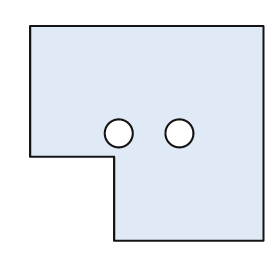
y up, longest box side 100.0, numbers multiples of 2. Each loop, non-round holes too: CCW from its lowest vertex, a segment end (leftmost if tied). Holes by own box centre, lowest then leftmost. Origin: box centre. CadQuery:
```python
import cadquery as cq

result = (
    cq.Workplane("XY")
    .moveTo(-14.0, -46.0)
    .lineTo(50.0, -46.0)
    .lineTo(50.0, 46.0)
    .lineTo(-50.0, 46.0)
    .lineTo(-50.0, -10.0)
    .lineTo(-14.0, -10.0)
    .close()
    .moveTo(-12.0, 0.0)
    .circle(6.0)
    .moveTo(14.0, 0.0)
    .circle(6.0)
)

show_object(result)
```